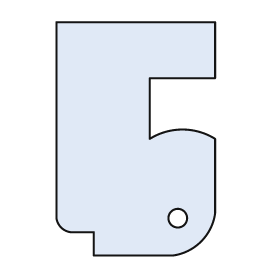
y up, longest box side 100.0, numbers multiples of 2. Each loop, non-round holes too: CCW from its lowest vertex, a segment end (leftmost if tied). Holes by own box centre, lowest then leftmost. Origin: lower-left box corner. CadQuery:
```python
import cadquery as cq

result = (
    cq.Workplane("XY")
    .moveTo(16.0, 0.0)
    .lineTo(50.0, 0.0)
    .threePointArc((62.0, 6.0), (68.0, 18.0))
    .lineTo(68.0, 50.0)
    .threePointArc((54.0, 54.0), (40.0, 50.0))
    .lineTo(40.0, 76.0)
    .lineTo(68.0, 76.0)
    .lineTo(68.0, 100.0)
    .lineTo(0.0, 100.0)
    .lineTo(0.0, 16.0)
    .threePointArc((2.0, 12.0), (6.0, 10.0))
    .lineTo(16.0, 10.0)
    .close()
    .moveTo(52.0, 16.0)
    .circle(4.0)
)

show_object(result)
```